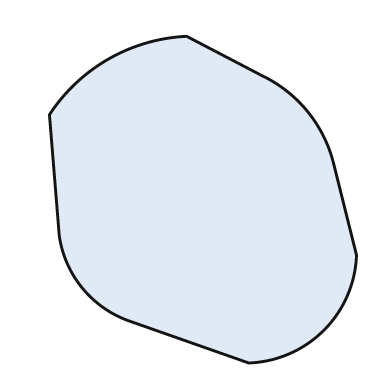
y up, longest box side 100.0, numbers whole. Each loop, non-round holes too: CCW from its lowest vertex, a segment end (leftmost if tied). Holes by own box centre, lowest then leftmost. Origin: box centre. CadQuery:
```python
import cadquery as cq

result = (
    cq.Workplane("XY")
    .moveTo(14.0, -50.0)
    .threePointArc((37.0, -40.0), (47.0, -17.0))
    .lineTo(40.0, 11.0)
    .threePointArc((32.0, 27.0), (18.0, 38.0))
    .lineTo(-5.0, 50.0)
    .threePointArc((-29.0, 43.0), (-47.0, 26.0))
    .lineTo(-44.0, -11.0)
    .threePointArc((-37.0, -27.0), (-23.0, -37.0))
    .close()
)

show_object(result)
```